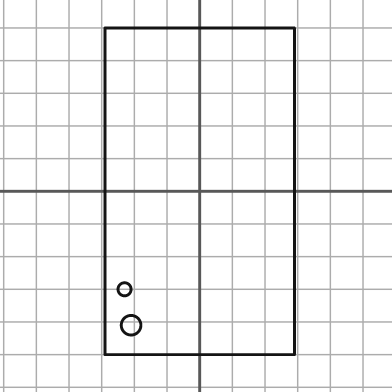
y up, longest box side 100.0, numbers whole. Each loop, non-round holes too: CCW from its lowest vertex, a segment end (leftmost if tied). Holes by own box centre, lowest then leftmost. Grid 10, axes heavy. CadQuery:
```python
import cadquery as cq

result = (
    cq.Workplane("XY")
    .moveTo(-29.0, -50.0)
    .lineTo(29.0, -50.0)
    .lineTo(29.0, 50.0)
    .lineTo(-29.0, 50.0)
    .close()
    .moveTo(-21.0, -41.0)
    .circle(3.0)
    .moveTo(-23.0, -30.0)
    .circle(2.0)
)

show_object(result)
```